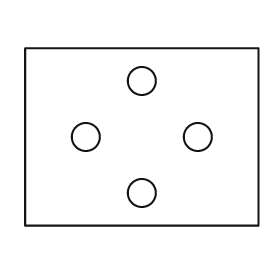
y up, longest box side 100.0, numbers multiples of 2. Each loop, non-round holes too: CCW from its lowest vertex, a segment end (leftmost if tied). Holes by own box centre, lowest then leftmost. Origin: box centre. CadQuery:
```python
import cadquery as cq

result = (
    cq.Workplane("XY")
    .moveTo(-50.0, -38.0)
    .lineTo(50.0, -38.0)
    .lineTo(50.0, 38.0)
    .lineTo(-50.0, 38.0)
    .close()
    .moveTo(0.0, -24.0)
    .circle(6.0)
    .moveTo(-24.0, 0.0)
    .circle(6.0)
    .moveTo(24.0, 0.0)
    .circle(6.0)
    .moveTo(0.0, 24.0)
    .circle(6.0)
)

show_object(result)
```